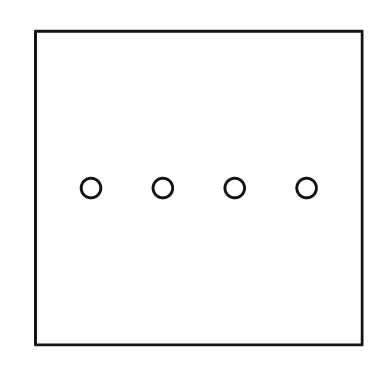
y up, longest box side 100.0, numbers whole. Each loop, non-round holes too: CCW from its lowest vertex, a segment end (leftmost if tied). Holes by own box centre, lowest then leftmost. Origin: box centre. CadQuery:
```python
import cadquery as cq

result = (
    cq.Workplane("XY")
    .moveTo(-50.0, -48.0)
    .lineTo(50.0, -48.0)
    .lineTo(50.0, 48.0)
    .lineTo(-50.0, 48.0)
    .close()
    .moveTo(-33.0, 0.0)
    .circle(3.0)
    .moveTo(-11.0, 0.0)
    .circle(3.0)
    .moveTo(11.0, 0.0)
    .circle(3.0)
    .moveTo(33.0, 0.0)
    .circle(3.0)
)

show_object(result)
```